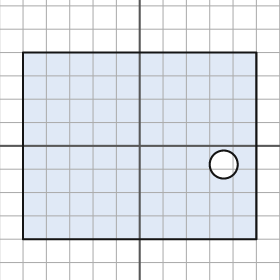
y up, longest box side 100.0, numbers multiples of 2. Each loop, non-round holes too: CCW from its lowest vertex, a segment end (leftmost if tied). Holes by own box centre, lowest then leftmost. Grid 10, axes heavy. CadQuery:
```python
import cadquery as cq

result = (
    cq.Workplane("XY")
    .moveTo(-50.0, -40.0)
    .lineTo(50.0, -40.0)
    .lineTo(50.0, 40.0)
    .lineTo(-50.0, 40.0)
    .close()
    .moveTo(36.0, -8.0)
    .circle(6.0)
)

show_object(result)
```